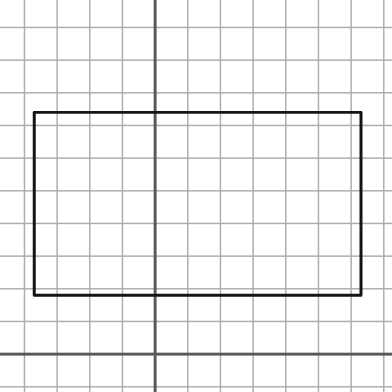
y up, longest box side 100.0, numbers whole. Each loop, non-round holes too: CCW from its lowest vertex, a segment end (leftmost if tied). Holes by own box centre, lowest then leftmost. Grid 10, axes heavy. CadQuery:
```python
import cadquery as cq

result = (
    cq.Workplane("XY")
    .moveTo(-37.0, 18.0)
    .lineTo(63.0, 18.0)
    .lineTo(63.0, 74.0)
    .lineTo(-37.0, 74.0)
    .close()
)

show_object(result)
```